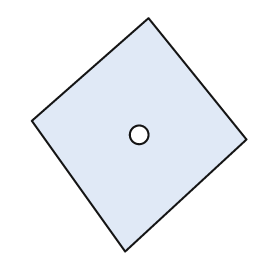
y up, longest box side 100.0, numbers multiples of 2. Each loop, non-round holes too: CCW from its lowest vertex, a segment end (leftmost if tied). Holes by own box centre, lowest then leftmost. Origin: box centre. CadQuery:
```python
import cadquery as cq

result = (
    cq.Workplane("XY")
    .moveTo(-6.0, -50.0)
    .lineTo(46.0, -2.0)
    .lineTo(4.0, 50.0)
    .lineTo(-46.0, 6.0)
    .close()
    .moveTo(0.0, 0.0)
    .circle(4.0)
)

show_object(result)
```